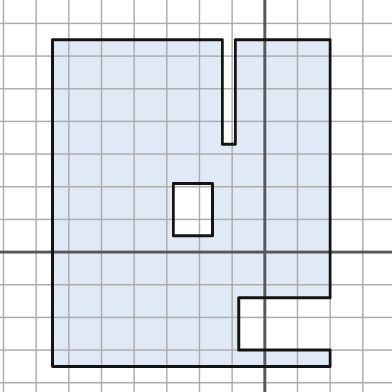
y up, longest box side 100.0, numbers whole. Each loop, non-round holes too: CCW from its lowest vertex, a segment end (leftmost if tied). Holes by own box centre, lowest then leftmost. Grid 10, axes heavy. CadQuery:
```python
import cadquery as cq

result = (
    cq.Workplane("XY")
    .moveTo(-65.0, -35.0)
    .lineTo(20.0, -35.0)
    .lineTo(20.0, -30.0)
    .lineTo(-8.0, -30.0)
    .lineTo(-8.0, -14.0)
    .lineTo(20.0, -14.0)
    .lineTo(20.0, 65.0)
    .lineTo(-9.0, 65.0)
    .lineTo(-9.0, 33.0)
    .lineTo(-13.0, 33.0)
    .lineTo(-13.0, 65.0)
    .lineTo(-65.0, 65.0)
    .close()
    .moveTo(-28.0, 5.0)
    .lineTo(-16.0, 5.0)
    .lineTo(-16.0, 21.0)
    .lineTo(-28.0, 21.0)
    .close()
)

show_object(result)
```